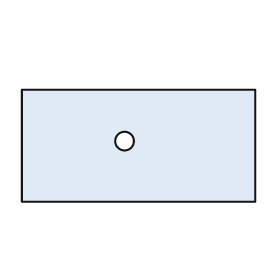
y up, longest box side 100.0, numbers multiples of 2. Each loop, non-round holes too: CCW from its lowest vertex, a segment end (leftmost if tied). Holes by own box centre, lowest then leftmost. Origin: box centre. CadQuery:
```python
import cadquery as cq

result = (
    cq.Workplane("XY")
    .moveTo(-50.0, -24.0)
    .lineTo(50.0, -24.0)
    .lineTo(50.0, 24.0)
    .lineTo(-50.0, 24.0)
    .close()
    .moveTo(-6.0, 2.0)
    .circle(4.0)
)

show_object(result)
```